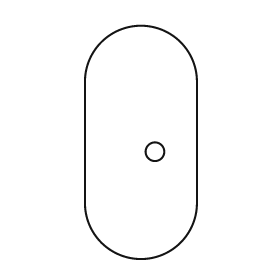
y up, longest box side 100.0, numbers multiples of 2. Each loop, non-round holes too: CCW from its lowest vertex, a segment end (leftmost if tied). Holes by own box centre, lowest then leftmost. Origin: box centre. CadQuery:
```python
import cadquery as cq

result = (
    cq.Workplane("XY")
    .moveTo(-24.0, -26.0)
    .threePointArc((0.0, -50.0), (24.0, -26.0))
    .lineTo(24.0, 26.0)
    .threePointArc((0.0, 50.0), (-24.0, 26.0))
    .close()
    .moveTo(6.0, -4.0)
    .circle(4.0)
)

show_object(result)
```